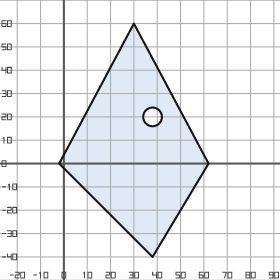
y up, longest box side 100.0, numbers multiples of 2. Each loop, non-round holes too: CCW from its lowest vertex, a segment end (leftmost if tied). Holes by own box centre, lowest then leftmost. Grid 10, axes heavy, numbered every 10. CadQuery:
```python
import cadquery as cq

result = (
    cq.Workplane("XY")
    .moveTo(38.0, -40.0)
    .lineTo(62.0, 0.0)
    .lineTo(30.0, 60.0)
    .lineTo(-2.0, 0.0)
    .close()
    .moveTo(38.0, 20.0)
    .circle(4.0)
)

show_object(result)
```